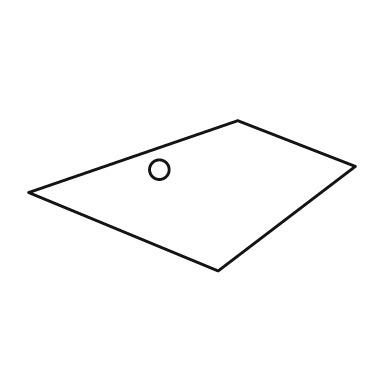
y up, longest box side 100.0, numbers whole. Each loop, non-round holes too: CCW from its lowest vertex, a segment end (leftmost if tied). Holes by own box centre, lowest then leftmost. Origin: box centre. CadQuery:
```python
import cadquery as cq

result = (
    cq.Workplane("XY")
    .moveTo(8.0, -23.0)
    .lineTo(50.0, 9.0)
    .lineTo(14.0, 23.0)
    .lineTo(-50.0, 1.0)
    .close()
    .moveTo(-10.0, 8.0)
    .circle(3.0)
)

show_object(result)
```